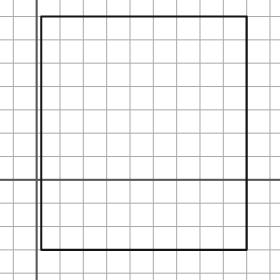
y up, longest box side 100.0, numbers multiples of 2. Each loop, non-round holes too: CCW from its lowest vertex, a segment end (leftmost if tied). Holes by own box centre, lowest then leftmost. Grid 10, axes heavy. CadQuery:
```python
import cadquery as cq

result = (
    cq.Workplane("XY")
    .moveTo(2.0, -30.0)
    .lineTo(90.0, -30.0)
    .lineTo(90.0, 70.0)
    .lineTo(2.0, 70.0)
    .close()
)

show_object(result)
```